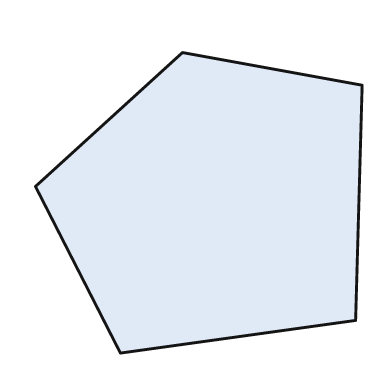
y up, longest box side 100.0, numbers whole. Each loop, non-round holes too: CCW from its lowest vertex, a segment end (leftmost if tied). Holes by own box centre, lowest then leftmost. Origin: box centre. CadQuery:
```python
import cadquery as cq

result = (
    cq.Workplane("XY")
    .moveTo(-24.0, -46.0)
    .lineTo(48.0, -36.0)
    .lineTo(50.0, 36.0)
    .lineTo(-5.0, 46.0)
    .lineTo(-50.0, 5.0)
    .close()
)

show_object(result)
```